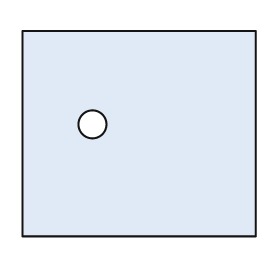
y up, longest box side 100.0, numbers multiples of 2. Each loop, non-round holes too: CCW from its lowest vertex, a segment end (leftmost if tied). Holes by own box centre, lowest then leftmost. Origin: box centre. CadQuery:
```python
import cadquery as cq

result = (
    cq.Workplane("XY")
    .moveTo(-50.0, -44.0)
    .lineTo(50.0, -44.0)
    .lineTo(50.0, 44.0)
    .lineTo(-50.0, 44.0)
    .close()
    .moveTo(-20.0, 4.0)
    .circle(6.0)
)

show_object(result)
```